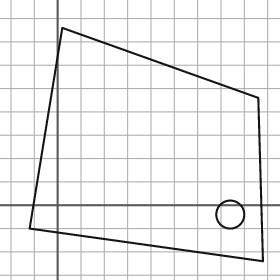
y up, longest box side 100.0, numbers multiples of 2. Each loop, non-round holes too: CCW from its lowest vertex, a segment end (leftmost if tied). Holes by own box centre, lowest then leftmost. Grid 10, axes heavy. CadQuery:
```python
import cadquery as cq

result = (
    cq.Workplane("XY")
    .moveTo(88.0, -24.0)
    .lineTo(86.0, 46.0)
    .lineTo(2.0, 76.0)
    .lineTo(-12.0, -10.0)
    .close()
    .moveTo(74.0, -4.0)
    .circle(6.0)
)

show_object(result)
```